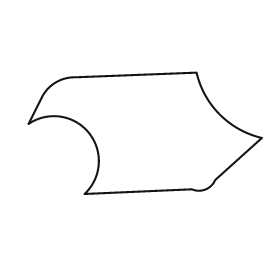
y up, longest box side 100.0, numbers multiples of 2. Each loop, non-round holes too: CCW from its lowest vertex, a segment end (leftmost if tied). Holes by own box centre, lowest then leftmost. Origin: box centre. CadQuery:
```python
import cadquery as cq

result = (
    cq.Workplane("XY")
    .moveTo(-26.0, -26.0)
    .lineTo(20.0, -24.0)
    .threePointArc((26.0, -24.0), (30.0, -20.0))
    .lineTo(50.0, -2.0)
    .threePointArc((32.0, 8.0), (22.0, 26.0))
    .lineTo(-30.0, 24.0)
    .threePointArc((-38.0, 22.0), (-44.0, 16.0))
    .lineTo(-50.0, 4.0)
    .threePointArc((-24.0, 0.0), (-26.0, -26.0))
    .close()
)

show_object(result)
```